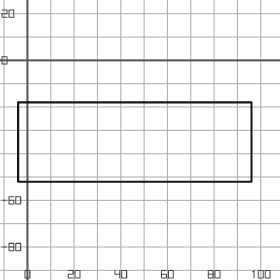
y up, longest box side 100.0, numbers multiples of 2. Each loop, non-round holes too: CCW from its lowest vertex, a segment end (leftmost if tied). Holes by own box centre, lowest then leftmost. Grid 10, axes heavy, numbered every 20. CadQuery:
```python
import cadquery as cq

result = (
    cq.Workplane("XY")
    .moveTo(-4.0, -52.0)
    .lineTo(96.0, -52.0)
    .lineTo(96.0, -18.0)
    .lineTo(-4.0, -18.0)
    .close()
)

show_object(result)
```